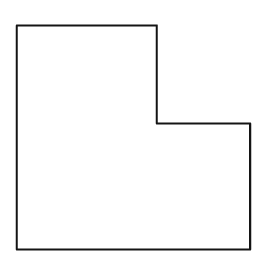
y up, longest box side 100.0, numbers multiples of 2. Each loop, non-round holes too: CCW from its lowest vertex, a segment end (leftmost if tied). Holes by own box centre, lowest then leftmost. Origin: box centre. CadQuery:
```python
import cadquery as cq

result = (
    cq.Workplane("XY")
    .moveTo(-50.0, -48.0)
    .lineTo(50.0, -48.0)
    .lineTo(50.0, 6.0)
    .lineTo(10.0, 6.0)
    .lineTo(10.0, 48.0)
    .lineTo(-50.0, 48.0)
    .close()
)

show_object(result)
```